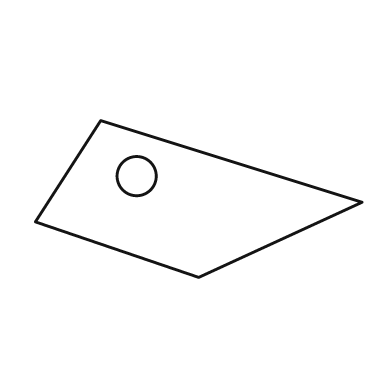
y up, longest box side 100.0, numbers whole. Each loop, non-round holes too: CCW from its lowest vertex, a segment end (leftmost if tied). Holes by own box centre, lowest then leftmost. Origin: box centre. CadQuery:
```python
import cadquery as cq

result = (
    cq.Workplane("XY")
    .moveTo(0.0, -24.0)
    .lineTo(50.0, -1.0)
    .lineTo(-30.0, 24.0)
    .lineTo(-50.0, -7.0)
    .close()
    .moveTo(-19.0, 7.0)
    .circle(6.0)
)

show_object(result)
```